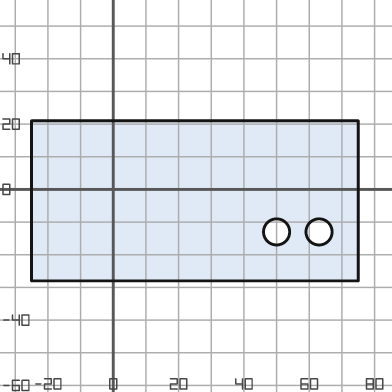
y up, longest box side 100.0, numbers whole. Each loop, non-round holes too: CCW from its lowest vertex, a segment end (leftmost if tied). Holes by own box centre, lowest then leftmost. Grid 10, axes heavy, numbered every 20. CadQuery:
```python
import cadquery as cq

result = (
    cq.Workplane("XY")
    .moveTo(-25.0, -28.0)
    .lineTo(75.0, -28.0)
    .lineTo(75.0, 21.0)
    .lineTo(-25.0, 21.0)
    .close()
    .moveTo(50.0, -13.0)
    .circle(4.0)
    .moveTo(63.0, -13.0)
    .circle(4.0)
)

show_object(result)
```